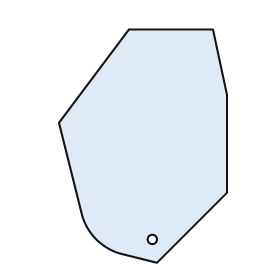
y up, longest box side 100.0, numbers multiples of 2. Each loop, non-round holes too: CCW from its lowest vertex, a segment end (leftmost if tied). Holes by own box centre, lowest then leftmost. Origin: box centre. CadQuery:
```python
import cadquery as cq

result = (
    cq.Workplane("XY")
    .moveTo(6.0, -50.0)
    .lineTo(36.0, -20.0)
    .lineTo(36.0, 22.0)
    .lineTo(30.0, 50.0)
    .lineTo(-6.0, 50.0)
    .lineTo(-36.0, 10.0)
    .lineTo(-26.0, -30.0)
    .threePointArc((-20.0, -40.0), (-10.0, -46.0))
    .close()
    .moveTo(4.0, -40.0)
    .circle(2.0)
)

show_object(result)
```